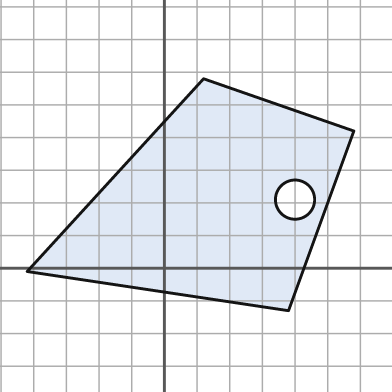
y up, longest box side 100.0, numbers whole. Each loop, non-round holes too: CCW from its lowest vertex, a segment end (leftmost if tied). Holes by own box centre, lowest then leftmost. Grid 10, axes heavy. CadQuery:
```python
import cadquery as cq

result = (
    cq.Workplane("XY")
    .moveTo(38.0, -13.0)
    .lineTo(58.0, 42.0)
    .lineTo(12.0, 58.0)
    .lineTo(-42.0, -1.0)
    .close()
    .moveTo(40.0, 21.0)
    .circle(6.0)
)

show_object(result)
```